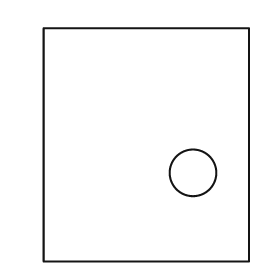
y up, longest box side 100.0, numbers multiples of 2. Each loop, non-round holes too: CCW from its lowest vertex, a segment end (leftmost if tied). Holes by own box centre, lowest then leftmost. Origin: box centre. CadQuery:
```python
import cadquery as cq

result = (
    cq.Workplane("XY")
    .moveTo(-44.0, -50.0)
    .lineTo(44.0, -50.0)
    .lineTo(44.0, 50.0)
    .lineTo(-44.0, 50.0)
    .close()
    .moveTo(20.0, -12.0)
    .circle(10.0)
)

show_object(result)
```